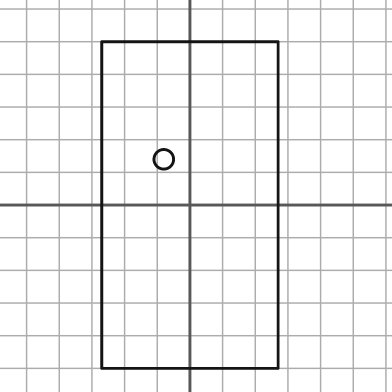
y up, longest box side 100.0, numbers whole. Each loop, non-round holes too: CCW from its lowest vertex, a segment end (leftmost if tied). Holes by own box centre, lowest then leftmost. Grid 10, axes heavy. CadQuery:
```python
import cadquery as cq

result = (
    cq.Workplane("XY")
    .moveTo(-27.0, -50.0)
    .lineTo(27.0, -50.0)
    .lineTo(27.0, 50.0)
    .lineTo(-27.0, 50.0)
    .close()
    .moveTo(-8.0, 14.0)
    .circle(3.0)
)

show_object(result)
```